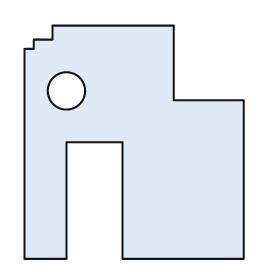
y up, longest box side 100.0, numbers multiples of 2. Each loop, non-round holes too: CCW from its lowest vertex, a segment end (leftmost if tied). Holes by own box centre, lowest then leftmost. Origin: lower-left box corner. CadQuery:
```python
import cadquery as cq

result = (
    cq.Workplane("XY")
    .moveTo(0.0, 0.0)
    .lineTo(18.0, 0.0)
    .lineTo(18.0, 50.0)
    .lineTo(42.0, 50.0)
    .lineTo(42.0, 0.0)
    .lineTo(94.0, 0.0)
    .lineTo(94.0, 68.0)
    .lineTo(64.0, 68.0)
    .lineTo(64.0, 100.0)
    .lineTo(12.0, 100.0)
    .lineTo(12.0, 94.0)
    .lineTo(4.0, 94.0)
    .lineTo(4.0, 90.0)
    .lineTo(0.0, 90.0)
    .close()
    .moveTo(18.0, 72.0)
    .circle(8.0)
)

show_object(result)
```